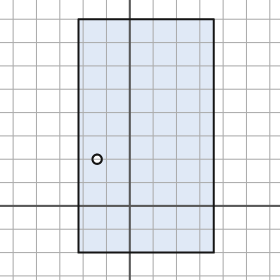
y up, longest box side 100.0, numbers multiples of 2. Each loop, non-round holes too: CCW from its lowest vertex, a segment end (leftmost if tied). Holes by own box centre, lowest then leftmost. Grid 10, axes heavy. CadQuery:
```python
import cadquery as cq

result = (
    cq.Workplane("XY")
    .moveTo(-22.0, -20.0)
    .lineTo(36.0, -20.0)
    .lineTo(36.0, 80.0)
    .lineTo(-22.0, 80.0)
    .close()
    .moveTo(-14.0, 20.0)
    .circle(2.0)
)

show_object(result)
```